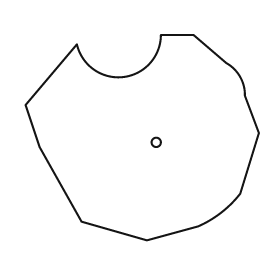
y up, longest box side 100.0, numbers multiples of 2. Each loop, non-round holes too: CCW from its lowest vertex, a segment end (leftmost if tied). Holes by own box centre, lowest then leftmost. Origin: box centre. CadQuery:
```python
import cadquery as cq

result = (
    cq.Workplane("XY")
    .moveTo(2.0, -44.0)
    .lineTo(24.0, -38.0)
    .threePointArc((34.0, -32.0), (42.0, -24.0))
    .lineTo(50.0, 2.0)
    .lineTo(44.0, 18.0)
    .threePointArc((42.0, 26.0), (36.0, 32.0))
    .lineTo(22.0, 44.0)
    .lineTo(8.0, 44.0)
    .threePointArc((-8.0, 26.0), (-28.0, 40.0))
    .lineTo(-50.0, 14.0)
    .lineTo(-44.0, -4.0)
    .lineTo(-26.0, -36.0)
    .close()
    .moveTo(6.0, -2.0)
    .circle(2.0)
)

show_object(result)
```